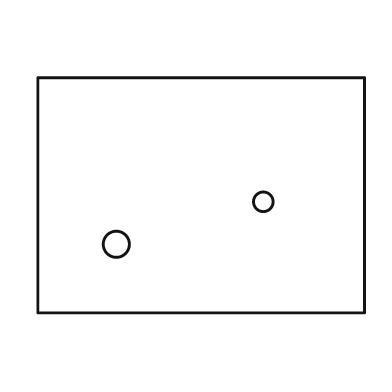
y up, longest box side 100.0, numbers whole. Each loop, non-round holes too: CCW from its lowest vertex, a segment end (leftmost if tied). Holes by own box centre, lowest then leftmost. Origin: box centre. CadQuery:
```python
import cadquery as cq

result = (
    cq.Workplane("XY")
    .moveTo(-50.0, -36.0)
    .lineTo(50.0, -36.0)
    .lineTo(50.0, 36.0)
    .lineTo(-50.0, 36.0)
    .close()
    .moveTo(-26.0, -15.0)
    .circle(4.0)
    .moveTo(19.0, -2.0)
    .circle(3.0)
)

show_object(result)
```